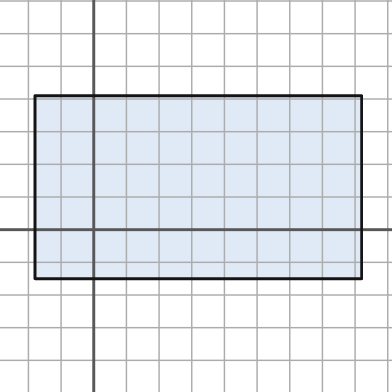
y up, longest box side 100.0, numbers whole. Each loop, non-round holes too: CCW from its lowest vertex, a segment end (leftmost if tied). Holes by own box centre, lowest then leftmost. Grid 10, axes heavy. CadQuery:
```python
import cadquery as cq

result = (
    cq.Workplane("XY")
    .moveTo(-18.0, -15.0)
    .lineTo(82.0, -15.0)
    .lineTo(82.0, 41.0)
    .lineTo(-18.0, 41.0)
    .close()
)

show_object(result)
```